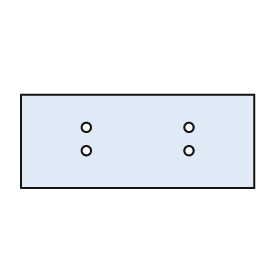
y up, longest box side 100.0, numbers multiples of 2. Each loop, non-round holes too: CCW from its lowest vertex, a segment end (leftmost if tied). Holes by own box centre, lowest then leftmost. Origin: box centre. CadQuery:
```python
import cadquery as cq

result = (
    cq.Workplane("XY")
    .moveTo(-50.0, -20.0)
    .lineTo(50.0, -20.0)
    .lineTo(50.0, 20.0)
    .lineTo(-50.0, 20.0)
    .close()
    .moveTo(-22.0, -4.0)
    .circle(2.0)
    .moveTo(22.0, -4.0)
    .circle(2.0)
    .moveTo(-22.0, 6.0)
    .circle(2.0)
    .moveTo(22.0, 6.0)
    .circle(2.0)
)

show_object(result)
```